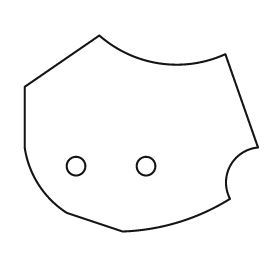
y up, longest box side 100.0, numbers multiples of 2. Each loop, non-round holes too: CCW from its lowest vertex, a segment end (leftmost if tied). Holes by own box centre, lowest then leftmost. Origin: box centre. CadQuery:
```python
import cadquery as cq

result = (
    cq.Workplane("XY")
    .moveTo(-8.0, -42.0)
    .threePointArc((16.0, -38.0), (38.0, -28.0))
    .threePointArc((38.0, -14.0), (50.0, -6.0))
    .lineTo(36.0, 34.0)
    .threePointArc((8.0, 30.0), (-18.0, 42.0))
    .lineTo(-50.0, 20.0)
    .lineTo(-50.0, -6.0)
    .threePointArc((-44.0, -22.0), (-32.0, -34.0))
    .close()
    .moveTo(-28.0, -14.0)
    .circle(4.0)
    .moveTo(2.0, -14.0)
    .circle(4.0)
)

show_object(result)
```